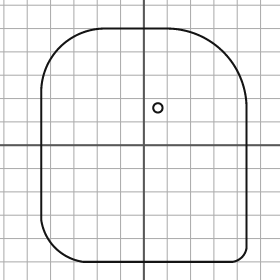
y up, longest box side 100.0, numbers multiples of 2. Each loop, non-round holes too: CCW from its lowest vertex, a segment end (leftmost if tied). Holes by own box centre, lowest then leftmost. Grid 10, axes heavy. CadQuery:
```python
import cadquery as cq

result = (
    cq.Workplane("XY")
    .moveTo(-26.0, -50.0)
    .lineTo(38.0, -50.0)
    .threePointArc((42.0, -48.0), (44.0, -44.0))
    .lineTo(44.0, 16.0)
    .threePointArc((34.0, 40.0), (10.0, 50.0))
    .lineTo(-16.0, 50.0)
    .threePointArc((-36.0, 42.0), (-44.0, 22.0))
    .lineTo(-44.0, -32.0)
    .threePointArc((-38.0, -44.0), (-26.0, -50.0))
    .close()
    .moveTo(6.0, 16.0)
    .circle(2.0)
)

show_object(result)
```